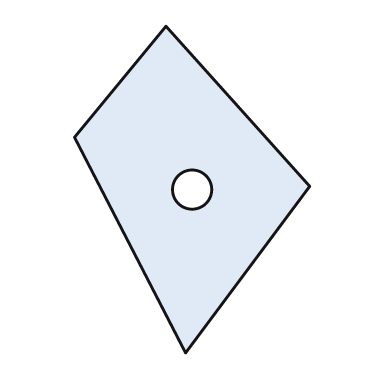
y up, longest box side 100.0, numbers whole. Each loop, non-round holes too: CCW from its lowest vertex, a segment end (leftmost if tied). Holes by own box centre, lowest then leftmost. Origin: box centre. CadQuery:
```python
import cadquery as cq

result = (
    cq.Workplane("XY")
    .moveTo(-2.0, -50.0)
    .lineTo(36.0, 1.0)
    .lineTo(-8.0, 50.0)
    .lineTo(-36.0, 16.0)
    .close()
    .moveTo(0.0, 0.0)
    .circle(6.0)
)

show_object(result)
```